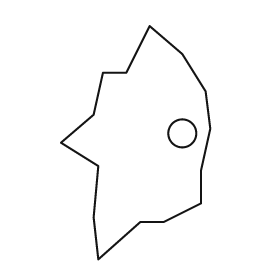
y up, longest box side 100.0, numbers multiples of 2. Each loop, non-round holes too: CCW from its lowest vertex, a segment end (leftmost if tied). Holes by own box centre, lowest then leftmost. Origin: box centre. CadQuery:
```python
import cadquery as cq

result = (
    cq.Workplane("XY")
    .moveTo(-16.0, -50.0)
    .lineTo(2.0, -34.0)
    .lineTo(12.0, -34.0)
    .lineTo(28.0, -26.0)
    .lineTo(28.0, -12.0)
    .lineTo(32.0, 6.0)
    .lineTo(30.0, 22.0)
    .lineTo(20.0, 38.0)
    .lineTo(6.0, 50.0)
    .lineTo(-4.0, 30.0)
    .lineTo(-14.0, 30.0)
    .lineTo(-18.0, 12.0)
    .lineTo(-32.0, 0.0)
    .lineTo(-16.0, -10.0)
    .lineTo(-18.0, -32.0)
    .close()
    .moveTo(20.0, 4.0)
    .circle(6.0)
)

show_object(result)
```